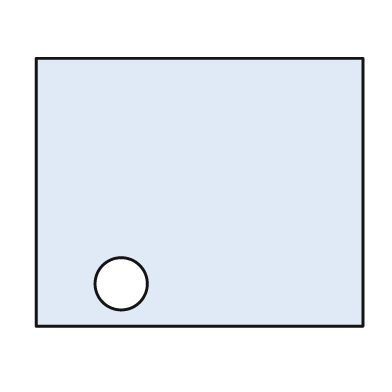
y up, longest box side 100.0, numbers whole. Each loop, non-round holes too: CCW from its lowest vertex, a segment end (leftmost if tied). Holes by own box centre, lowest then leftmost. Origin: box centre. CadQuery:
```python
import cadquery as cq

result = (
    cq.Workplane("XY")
    .moveTo(-50.0, -41.0)
    .lineTo(50.0, -41.0)
    .lineTo(50.0, 41.0)
    .lineTo(-50.0, 41.0)
    .close()
    .moveTo(-24.0, -28.0)
    .circle(8.0)
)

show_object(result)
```